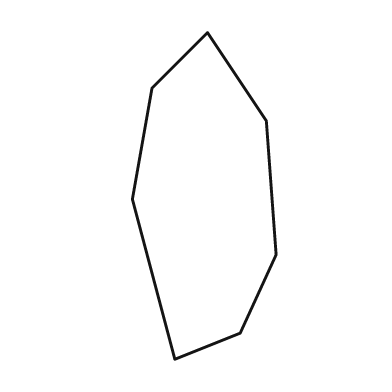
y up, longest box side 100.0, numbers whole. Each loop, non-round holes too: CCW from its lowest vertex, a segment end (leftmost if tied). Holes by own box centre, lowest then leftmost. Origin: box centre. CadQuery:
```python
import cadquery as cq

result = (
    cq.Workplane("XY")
    .moveTo(-9.0, -50.0)
    .lineTo(11.0, -42.0)
    .lineTo(22.0, -18.0)
    .lineTo(19.0, 23.0)
    .lineTo(1.0, 50.0)
    .lineTo(-16.0, 33.0)
    .lineTo(-22.0, -1.0)
    .close()
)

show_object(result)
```